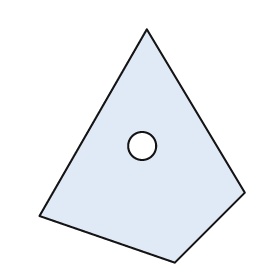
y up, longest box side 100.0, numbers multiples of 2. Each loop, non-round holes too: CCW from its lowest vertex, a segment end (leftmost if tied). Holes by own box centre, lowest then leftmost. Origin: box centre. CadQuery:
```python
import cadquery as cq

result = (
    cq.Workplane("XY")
    .moveTo(14.0, -50.0)
    .lineTo(44.0, -20.0)
    .lineTo(2.0, 50.0)
    .lineTo(-44.0, -30.0)
    .close()
    .moveTo(0.0, 0.0)
    .circle(6.0)
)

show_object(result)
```